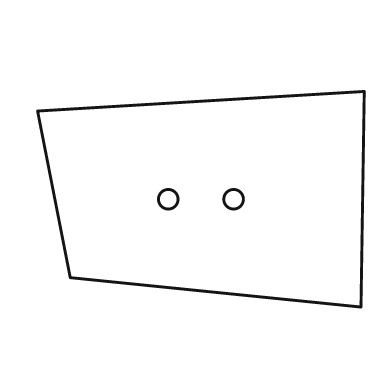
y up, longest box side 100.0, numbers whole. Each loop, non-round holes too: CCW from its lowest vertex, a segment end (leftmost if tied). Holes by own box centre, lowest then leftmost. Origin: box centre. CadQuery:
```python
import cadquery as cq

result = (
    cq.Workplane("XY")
    .moveTo(49.0, -33.0)
    .lineTo(50.0, 33.0)
    .lineTo(-50.0, 27.0)
    .lineTo(-40.0, -24.0)
    .close()
    .moveTo(-10.0, 0.0)
    .circle(3.0)
    .moveTo(10.0, 0.0)
    .circle(3.0)
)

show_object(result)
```